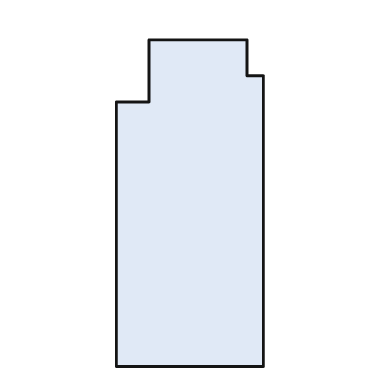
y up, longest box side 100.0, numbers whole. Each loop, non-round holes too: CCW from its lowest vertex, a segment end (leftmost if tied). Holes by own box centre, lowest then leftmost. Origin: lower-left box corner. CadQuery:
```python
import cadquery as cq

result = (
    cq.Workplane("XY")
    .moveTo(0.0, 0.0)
    .lineTo(45.0, 0.0)
    .lineTo(45.0, 89.0)
    .lineTo(40.0, 89.0)
    .lineTo(40.0, 100.0)
    .lineTo(10.0, 100.0)
    .lineTo(10.0, 81.0)
    .lineTo(0.0, 81.0)
    .close()
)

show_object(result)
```